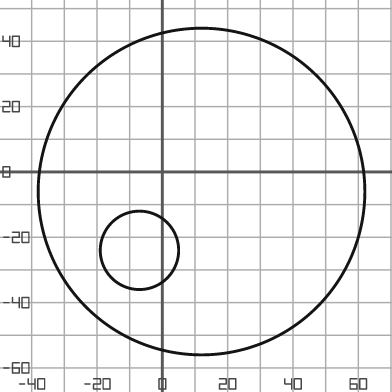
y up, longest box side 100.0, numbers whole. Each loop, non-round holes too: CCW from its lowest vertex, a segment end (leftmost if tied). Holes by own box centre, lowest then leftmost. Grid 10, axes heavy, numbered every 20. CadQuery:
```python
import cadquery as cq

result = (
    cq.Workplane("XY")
    .moveTo(12.0, -6.0)
    .circle(50.0)
    .moveTo(-7.0, -24.0)
    .circle(12.0)
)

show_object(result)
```